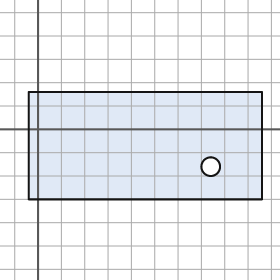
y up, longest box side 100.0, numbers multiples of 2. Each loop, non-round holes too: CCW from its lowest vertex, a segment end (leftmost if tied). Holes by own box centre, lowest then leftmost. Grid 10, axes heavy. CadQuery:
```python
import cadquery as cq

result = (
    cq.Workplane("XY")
    .moveTo(-4.0, -30.0)
    .lineTo(96.0, -30.0)
    .lineTo(96.0, 16.0)
    .lineTo(-4.0, 16.0)
    .close()
    .moveTo(74.0, -16.0)
    .circle(4.0)
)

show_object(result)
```